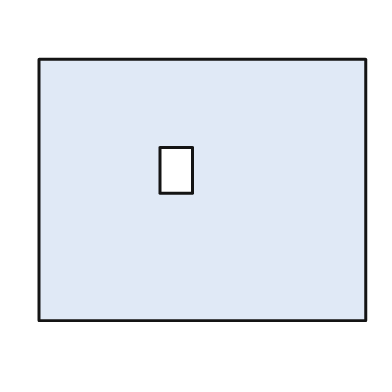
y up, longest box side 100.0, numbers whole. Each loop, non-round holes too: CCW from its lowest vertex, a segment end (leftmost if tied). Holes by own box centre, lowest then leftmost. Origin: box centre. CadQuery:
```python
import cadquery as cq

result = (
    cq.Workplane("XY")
    .moveTo(-50.0, -40.0)
    .lineTo(50.0, -40.0)
    .lineTo(50.0, 40.0)
    .lineTo(-50.0, 40.0)
    .close()
    .moveTo(-13.0, -1.0)
    .lineTo(-3.0, -1.0)
    .lineTo(-3.0, 13.0)
    .lineTo(-13.0, 13.0)
    .close()
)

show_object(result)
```